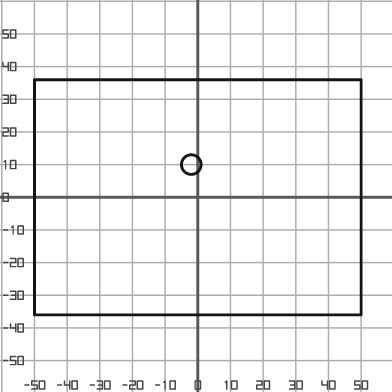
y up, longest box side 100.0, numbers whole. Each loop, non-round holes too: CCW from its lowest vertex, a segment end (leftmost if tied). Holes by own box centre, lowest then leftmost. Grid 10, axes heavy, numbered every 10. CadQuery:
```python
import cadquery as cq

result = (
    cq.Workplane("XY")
    .moveTo(-50.0, -36.0)
    .lineTo(50.0, -36.0)
    .lineTo(50.0, 36.0)
    .lineTo(-50.0, 36.0)
    .close()
    .moveTo(-2.0, 10.0)
    .circle(3.0)
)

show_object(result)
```